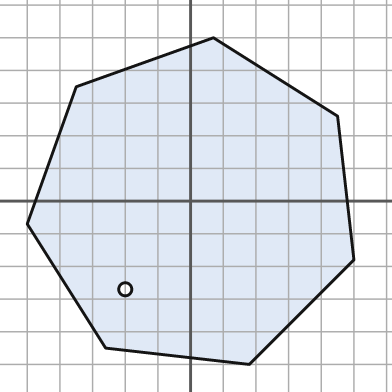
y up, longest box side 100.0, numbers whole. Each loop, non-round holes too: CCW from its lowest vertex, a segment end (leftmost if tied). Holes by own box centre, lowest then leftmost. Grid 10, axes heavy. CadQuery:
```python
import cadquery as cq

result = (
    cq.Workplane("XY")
    .moveTo(18.0, -50.0)
    .lineTo(50.0, -18.0)
    .lineTo(45.0, 26.0)
    .lineTo(7.0, 50.0)
    .lineTo(-35.0, 35.0)
    .lineTo(-50.0, -7.0)
    .lineTo(-26.0, -45.0)
    .close()
    .moveTo(-20.0, -27.0)
    .circle(2.0)
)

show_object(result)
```